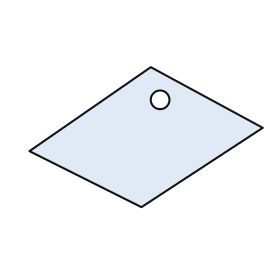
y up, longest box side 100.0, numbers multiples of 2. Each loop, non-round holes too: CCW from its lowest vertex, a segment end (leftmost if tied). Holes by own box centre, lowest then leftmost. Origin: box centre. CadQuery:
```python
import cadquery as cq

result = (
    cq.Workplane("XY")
    .moveTo(-2.0, -30.0)
    .lineTo(50.0, 4.0)
    .lineTo(2.0, 30.0)
    .lineTo(-50.0, -6.0)
    .close()
    .moveTo(6.0, 16.0)
    .circle(4.0)
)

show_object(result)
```